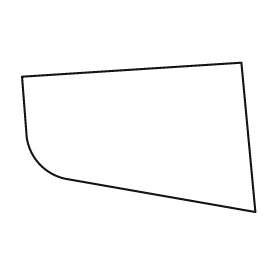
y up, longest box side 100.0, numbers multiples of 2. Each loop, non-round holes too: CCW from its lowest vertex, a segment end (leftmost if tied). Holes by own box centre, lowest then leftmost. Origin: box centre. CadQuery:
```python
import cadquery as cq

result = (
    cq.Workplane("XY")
    .moveTo(50.0, -32.0)
    .lineTo(44.0, 32.0)
    .lineTo(-50.0, 26.0)
    .lineTo(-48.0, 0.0)
    .threePointArc((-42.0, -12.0), (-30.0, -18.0))
    .close()
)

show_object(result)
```